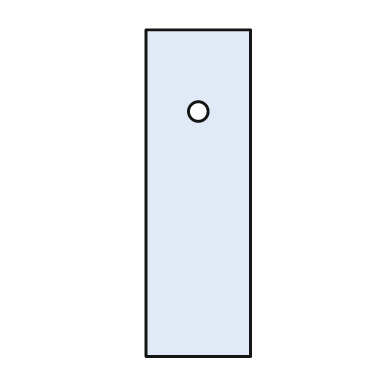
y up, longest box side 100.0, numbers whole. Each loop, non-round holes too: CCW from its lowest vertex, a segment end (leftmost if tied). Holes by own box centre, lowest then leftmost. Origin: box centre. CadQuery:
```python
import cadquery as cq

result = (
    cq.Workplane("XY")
    .moveTo(-16.0, -50.0)
    .lineTo(16.0, -50.0)
    .lineTo(16.0, 50.0)
    .lineTo(-16.0, 50.0)
    .close()
    .moveTo(0.0, 25.0)
    .circle(3.0)
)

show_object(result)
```